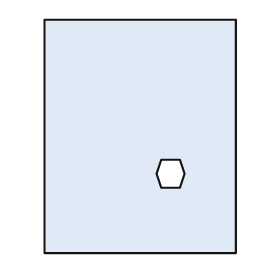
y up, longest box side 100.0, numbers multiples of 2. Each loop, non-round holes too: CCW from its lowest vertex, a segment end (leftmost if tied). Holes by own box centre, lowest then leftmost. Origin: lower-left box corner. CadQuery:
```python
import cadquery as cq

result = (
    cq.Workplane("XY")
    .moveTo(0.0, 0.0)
    .lineTo(82.0, 0.0)
    .lineTo(82.0, 100.0)
    .lineTo(0.0, 100.0)
    .close()
    .moveTo(50.0, 28.0)
    .lineTo(58.0, 28.0)
    .lineTo(60.0, 34.0)
    .lineTo(58.0, 40.0)
    .lineTo(50.0, 40.0)
    .lineTo(48.0, 34.0)
    .close()
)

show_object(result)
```